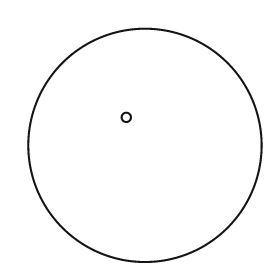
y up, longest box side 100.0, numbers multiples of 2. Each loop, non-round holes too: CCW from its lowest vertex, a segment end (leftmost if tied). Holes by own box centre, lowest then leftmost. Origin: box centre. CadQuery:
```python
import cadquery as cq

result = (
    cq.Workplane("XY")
    .moveTo(0.0, 0.0)
    .circle(50.0)
    .moveTo(-8.0, 12.0)
    .circle(2.0)
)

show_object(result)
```